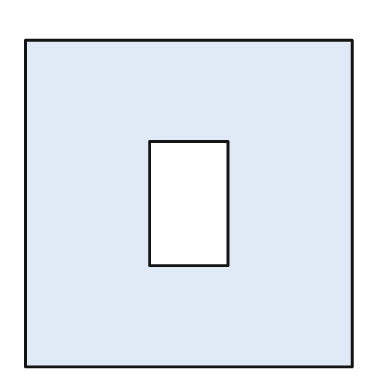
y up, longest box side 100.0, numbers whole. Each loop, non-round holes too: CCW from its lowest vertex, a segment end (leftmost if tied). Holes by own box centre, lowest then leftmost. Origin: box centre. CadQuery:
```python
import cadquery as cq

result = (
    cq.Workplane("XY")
    .moveTo(-50.0, -50.0)
    .lineTo(50.0, -50.0)
    .lineTo(50.0, 50.0)
    .lineTo(-50.0, 50.0)
    .close()
    .moveTo(-12.0, -19.0)
    .lineTo(12.0, -19.0)
    .lineTo(12.0, 19.0)
    .lineTo(-12.0, 19.0)
    .close()
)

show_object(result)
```